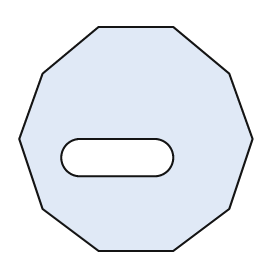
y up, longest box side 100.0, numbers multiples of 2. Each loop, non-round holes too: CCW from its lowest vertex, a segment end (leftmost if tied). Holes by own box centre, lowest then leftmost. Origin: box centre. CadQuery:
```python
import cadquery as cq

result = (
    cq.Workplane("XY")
    .moveTo(-16.0, -48.0)
    .lineTo(16.0, -48.0)
    .lineTo(40.0, -30.0)
    .lineTo(50.0, 0.0)
    .lineTo(40.0, 28.0)
    .lineTo(16.0, 48.0)
    .lineTo(-16.0, 48.0)
    .lineTo(-40.0, 28.0)
    .lineTo(-50.0, 0.0)
    .lineTo(-40.0, -30.0)
    .close()
    .moveTo(-24.0, -16.0)
    .lineTo(8.0, -16.0)
    .threePointArc((16.0, -8.0), (8.0, 0.0))
    .lineTo(-24.0, 0.0)
    .threePointArc((-32.0, -8.0), (-24.0, -16.0))
    .close()
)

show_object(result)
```